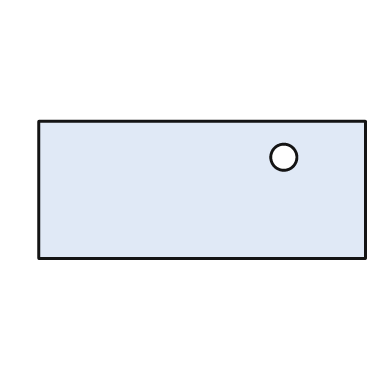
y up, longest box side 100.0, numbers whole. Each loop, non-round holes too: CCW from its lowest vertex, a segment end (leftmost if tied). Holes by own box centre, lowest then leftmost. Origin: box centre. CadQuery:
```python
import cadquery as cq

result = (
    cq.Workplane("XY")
    .moveTo(-50.0, -21.0)
    .lineTo(50.0, -21.0)
    .lineTo(50.0, 21.0)
    .lineTo(-50.0, 21.0)
    .close()
    .moveTo(25.0, 10.0)
    .circle(4.0)
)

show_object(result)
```